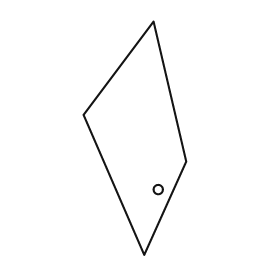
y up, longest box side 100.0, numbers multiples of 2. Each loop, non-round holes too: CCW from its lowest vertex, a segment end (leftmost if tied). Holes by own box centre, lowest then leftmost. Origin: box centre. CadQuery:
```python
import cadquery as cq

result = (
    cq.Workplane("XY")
    .moveTo(4.0, -50.0)
    .lineTo(22.0, -10.0)
    .lineTo(8.0, 50.0)
    .lineTo(-22.0, 10.0)
    .close()
    .moveTo(10.0, -22.0)
    .circle(2.0)
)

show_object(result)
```